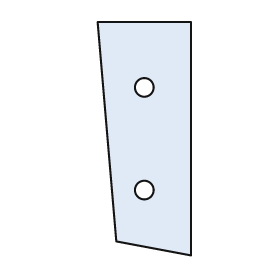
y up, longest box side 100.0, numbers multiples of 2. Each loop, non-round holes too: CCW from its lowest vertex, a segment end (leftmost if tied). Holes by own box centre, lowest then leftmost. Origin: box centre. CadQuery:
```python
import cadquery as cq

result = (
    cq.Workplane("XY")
    .moveTo(20.0, -50.0)
    .lineTo(20.0, 50.0)
    .lineTo(-20.0, 50.0)
    .lineTo(-12.0, -44.0)
    .close()
    .moveTo(0.0, -22.0)
    .circle(4.0)
    .moveTo(0.0, 22.0)
    .circle(4.0)
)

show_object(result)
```